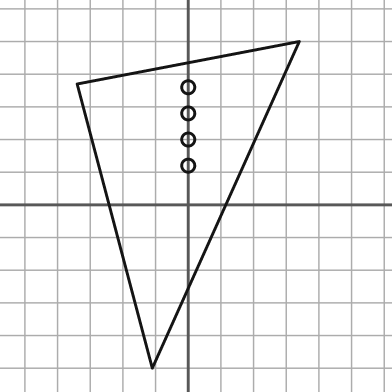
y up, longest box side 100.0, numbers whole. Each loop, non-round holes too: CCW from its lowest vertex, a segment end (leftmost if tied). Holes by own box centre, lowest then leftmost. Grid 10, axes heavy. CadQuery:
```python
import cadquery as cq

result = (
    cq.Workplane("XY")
    .moveTo(-11.0, -50.0)
    .lineTo(34.0, 50.0)
    .lineTo(-34.0, 37.0)
    .close()
    .moveTo(0.0, 12.0)
    .circle(2.0)
    .moveTo(0.0, 20.0)
    .circle(2.0)
    .moveTo(0.0, 28.0)
    .circle(2.0)
    .moveTo(0.0, 36.0)
    .circle(2.0)
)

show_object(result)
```